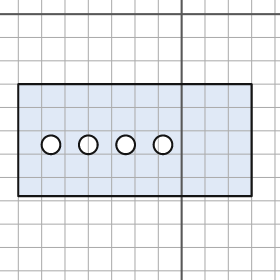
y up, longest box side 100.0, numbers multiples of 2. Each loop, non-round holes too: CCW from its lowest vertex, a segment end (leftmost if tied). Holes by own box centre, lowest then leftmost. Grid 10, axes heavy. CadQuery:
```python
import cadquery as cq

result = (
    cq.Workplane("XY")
    .moveTo(-70.0, -78.0)
    .lineTo(30.0, -78.0)
    .lineTo(30.0, -30.0)
    .lineTo(-70.0, -30.0)
    .close()
    .moveTo(-56.0, -56.0)
    .circle(4.0)
    .moveTo(-40.0, -56.0)
    .circle(4.0)
    .moveTo(-24.0, -56.0)
    .circle(4.0)
    .moveTo(-8.0, -56.0)
    .circle(4.0)
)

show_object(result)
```